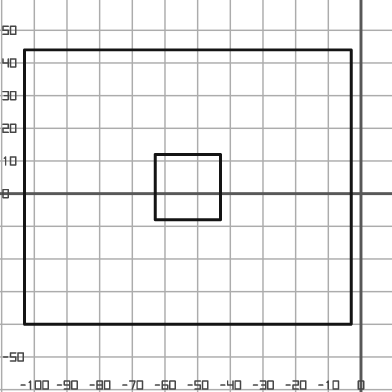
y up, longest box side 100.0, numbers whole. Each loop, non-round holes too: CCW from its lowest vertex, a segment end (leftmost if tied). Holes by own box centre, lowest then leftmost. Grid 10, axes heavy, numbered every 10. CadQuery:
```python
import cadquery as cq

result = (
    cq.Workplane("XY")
    .moveTo(-103.0, -40.0)
    .lineTo(-3.0, -40.0)
    .lineTo(-3.0, 44.0)
    .lineTo(-103.0, 44.0)
    .close()
    .moveTo(-63.0, -8.0)
    .lineTo(-43.0, -8.0)
    .lineTo(-43.0, 12.0)
    .lineTo(-63.0, 12.0)
    .close()
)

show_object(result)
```